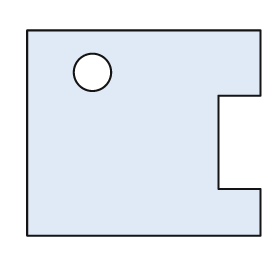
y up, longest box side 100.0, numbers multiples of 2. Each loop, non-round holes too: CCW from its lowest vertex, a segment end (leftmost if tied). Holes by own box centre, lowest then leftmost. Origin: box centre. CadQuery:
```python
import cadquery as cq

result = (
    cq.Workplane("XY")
    .moveTo(-50.0, -44.0)
    .lineTo(50.0, -44.0)
    .lineTo(50.0, -24.0)
    .lineTo(32.0, -24.0)
    .lineTo(32.0, 16.0)
    .lineTo(50.0, 16.0)
    .lineTo(50.0, 44.0)
    .lineTo(-50.0, 44.0)
    .close()
    .moveTo(-22.0, 26.0)
    .circle(8.0)
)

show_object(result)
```